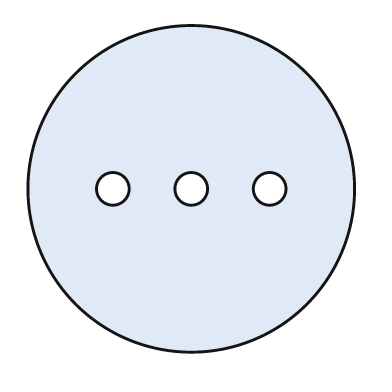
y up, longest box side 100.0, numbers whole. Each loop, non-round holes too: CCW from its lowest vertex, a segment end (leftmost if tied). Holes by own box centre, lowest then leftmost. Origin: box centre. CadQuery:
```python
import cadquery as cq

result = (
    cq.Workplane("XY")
    .moveTo(0.0, 0.0)
    .circle(50.0)
    .moveTo(-24.0, 0.0)
    .circle(5.0)
    .moveTo(0.0, 0.0)
    .circle(5.0)
    .moveTo(24.0, 0.0)
    .circle(5.0)
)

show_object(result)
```